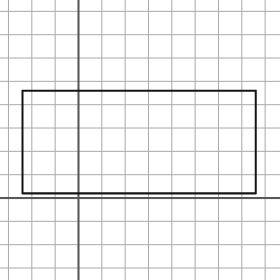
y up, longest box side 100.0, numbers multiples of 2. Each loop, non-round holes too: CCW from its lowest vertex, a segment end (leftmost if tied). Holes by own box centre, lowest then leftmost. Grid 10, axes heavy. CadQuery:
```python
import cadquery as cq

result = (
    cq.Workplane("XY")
    .moveTo(-24.0, 2.0)
    .lineTo(76.0, 2.0)
    .lineTo(76.0, 46.0)
    .lineTo(-24.0, 46.0)
    .close()
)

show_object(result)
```